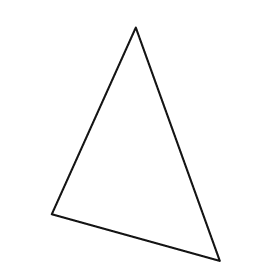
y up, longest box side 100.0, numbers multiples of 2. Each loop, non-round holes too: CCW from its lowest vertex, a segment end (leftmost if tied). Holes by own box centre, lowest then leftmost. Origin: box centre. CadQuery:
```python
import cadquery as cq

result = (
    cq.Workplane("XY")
    .moveTo(36.0, -50.0)
    .lineTo(0.0, 50.0)
    .lineTo(-36.0, -30.0)
    .close()
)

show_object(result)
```